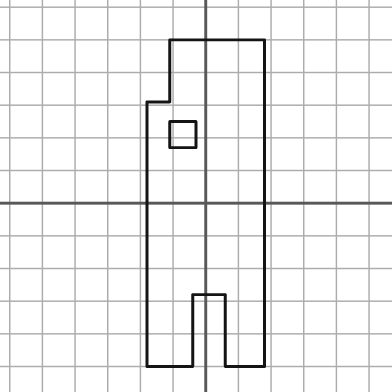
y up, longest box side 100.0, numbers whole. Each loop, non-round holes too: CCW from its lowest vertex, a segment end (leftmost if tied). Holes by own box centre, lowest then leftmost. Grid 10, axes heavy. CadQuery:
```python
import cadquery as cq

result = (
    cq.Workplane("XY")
    .moveTo(-18.0, -50.0)
    .lineTo(-4.0, -50.0)
    .lineTo(-4.0, -28.0)
    .lineTo(6.0, -28.0)
    .lineTo(6.0, -50.0)
    .lineTo(18.0, -50.0)
    .lineTo(18.0, 50.0)
    .lineTo(-11.0, 50.0)
    .lineTo(-11.0, 31.0)
    .lineTo(-18.0, 31.0)
    .close()
    .moveTo(-11.0, 17.0)
    .lineTo(-3.0, 17.0)
    .lineTo(-3.0, 25.0)
    .lineTo(-11.0, 25.0)
    .close()
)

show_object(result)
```